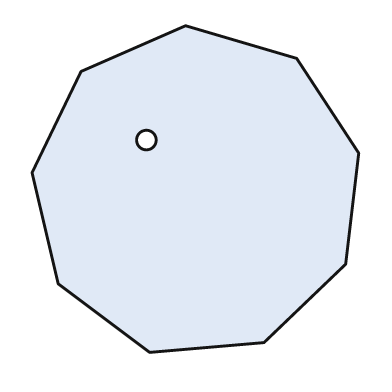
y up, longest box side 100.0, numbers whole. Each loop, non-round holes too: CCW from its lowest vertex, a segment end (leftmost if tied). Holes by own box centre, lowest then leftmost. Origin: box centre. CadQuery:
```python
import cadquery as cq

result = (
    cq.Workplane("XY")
    .moveTo(-14.0, -50.0)
    .lineTo(21.0, -47.0)
    .lineTo(46.0, -23.0)
    .lineTo(50.0, 11.0)
    .lineTo(31.0, 40.0)
    .lineTo(-3.0, 50.0)
    .lineTo(-35.0, 36.0)
    .lineTo(-50.0, 5.0)
    .lineTo(-42.0, -29.0)
    .close()
    .moveTo(-15.0, 15.0)
    .circle(3.0)
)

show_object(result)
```